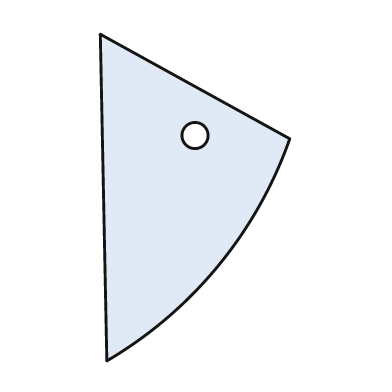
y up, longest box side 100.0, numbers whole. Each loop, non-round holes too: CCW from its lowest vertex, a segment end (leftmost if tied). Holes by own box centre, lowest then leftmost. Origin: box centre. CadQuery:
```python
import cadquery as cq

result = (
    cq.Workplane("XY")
    .moveTo(-27.0, -50.0)
    .threePointArc((7.0, -21.0), (29.0, 18.0))
    .lineTo(-29.0, 50.0)
    .close()
    .moveTo(0.0, 19.0)
    .circle(4.0)
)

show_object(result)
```